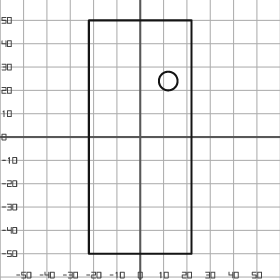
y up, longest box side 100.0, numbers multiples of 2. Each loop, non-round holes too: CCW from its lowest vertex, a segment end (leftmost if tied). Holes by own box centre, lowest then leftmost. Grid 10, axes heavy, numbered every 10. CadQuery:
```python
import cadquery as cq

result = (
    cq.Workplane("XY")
    .moveTo(-22.0, -50.0)
    .lineTo(22.0, -50.0)
    .lineTo(22.0, 50.0)
    .lineTo(-22.0, 50.0)
    .close()
    .moveTo(12.0, 24.0)
    .circle(4.0)
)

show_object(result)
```